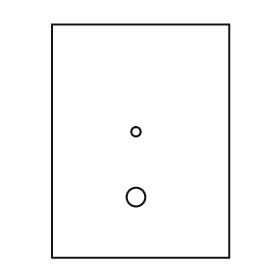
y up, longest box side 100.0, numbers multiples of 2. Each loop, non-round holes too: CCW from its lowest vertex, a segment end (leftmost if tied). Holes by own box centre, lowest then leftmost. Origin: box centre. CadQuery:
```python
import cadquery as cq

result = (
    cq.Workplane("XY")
    .moveTo(-38.0, -50.0)
    .lineTo(38.0, -50.0)
    .lineTo(38.0, 50.0)
    .lineTo(-38.0, 50.0)
    .close()
    .moveTo(-2.0, -24.0)
    .circle(4.0)
    .moveTo(-2.0, 4.0)
    .circle(2.0)
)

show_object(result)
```